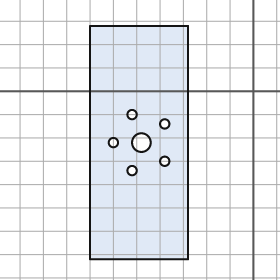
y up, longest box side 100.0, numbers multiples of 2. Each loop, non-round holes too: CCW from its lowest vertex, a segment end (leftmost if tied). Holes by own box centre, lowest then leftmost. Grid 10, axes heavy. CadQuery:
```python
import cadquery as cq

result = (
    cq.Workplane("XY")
    .moveTo(-70.0, -72.0)
    .lineTo(-28.0, -72.0)
    .lineTo(-28.0, 28.0)
    .lineTo(-70.0, 28.0)
    .close()
    .moveTo(-52.0, -34.0)
    .circle(2.0)
    .moveTo(-38.0, -30.0)
    .circle(2.0)
    .moveTo(-60.0, -22.0)
    .circle(2.0)
    .moveTo(-48.0, -22.0)
    .circle(4.0)
    .moveTo(-38.0, -14.0)
    .circle(2.0)
    .moveTo(-52.0, -10.0)
    .circle(2.0)
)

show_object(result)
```